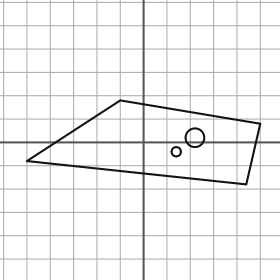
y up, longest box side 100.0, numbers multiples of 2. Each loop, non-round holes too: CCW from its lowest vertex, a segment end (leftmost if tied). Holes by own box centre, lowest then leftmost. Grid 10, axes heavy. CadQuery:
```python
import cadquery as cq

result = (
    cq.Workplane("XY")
    .moveTo(44.0, -18.0)
    .lineTo(50.0, 8.0)
    .lineTo(-10.0, 18.0)
    .lineTo(-50.0, -8.0)
    .close()
    .moveTo(14.0, -4.0)
    .circle(2.0)
    .moveTo(22.0, 2.0)
    .circle(4.0)
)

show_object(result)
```